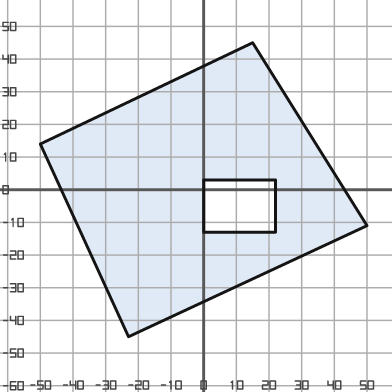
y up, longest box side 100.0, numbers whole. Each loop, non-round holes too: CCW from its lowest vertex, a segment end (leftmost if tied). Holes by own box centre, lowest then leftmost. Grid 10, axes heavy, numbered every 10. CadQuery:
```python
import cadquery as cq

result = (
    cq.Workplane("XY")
    .moveTo(-23.0, -45.0)
    .lineTo(50.0, -11.0)
    .lineTo(15.0, 45.0)
    .lineTo(-50.0, 14.0)
    .close()
    .moveTo(0.0, -13.0)
    .lineTo(22.0, -13.0)
    .lineTo(22.0, 3.0)
    .lineTo(0.0, 3.0)
    .close()
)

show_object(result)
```